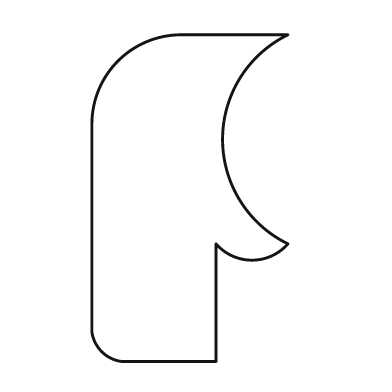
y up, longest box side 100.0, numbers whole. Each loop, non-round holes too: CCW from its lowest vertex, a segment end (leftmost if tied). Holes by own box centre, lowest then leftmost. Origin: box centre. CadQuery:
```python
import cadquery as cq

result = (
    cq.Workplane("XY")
    .moveTo(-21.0, -50.0)
    .lineTo(8.0, -50.0)
    .lineTo(8.0, -14.0)
    .threePointArc((19.0, -19.0), (30.0, -14.0))
    .threePointArc((10.0, 18.0), (30.0, 50.0))
    .lineTo(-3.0, 50.0)
    .threePointArc((-22.0, 42.0), (-30.0, 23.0))
    .lineTo(-30.0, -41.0)
    .threePointArc((-27.0, -47.0), (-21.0, -50.0))
    .close()
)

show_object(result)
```